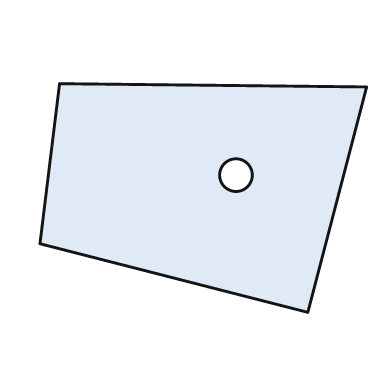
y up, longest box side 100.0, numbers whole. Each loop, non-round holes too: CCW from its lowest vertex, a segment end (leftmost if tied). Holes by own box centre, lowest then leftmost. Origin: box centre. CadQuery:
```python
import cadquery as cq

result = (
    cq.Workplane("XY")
    .moveTo(32.0, -35.0)
    .lineTo(50.0, 34.0)
    .lineTo(-44.0, 35.0)
    .lineTo(-50.0, -14.0)
    .close()
    .moveTo(10.0, 7.0)
    .circle(5.0)
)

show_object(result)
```